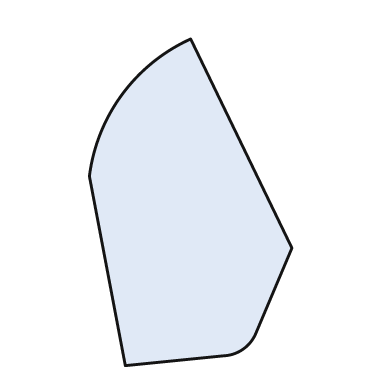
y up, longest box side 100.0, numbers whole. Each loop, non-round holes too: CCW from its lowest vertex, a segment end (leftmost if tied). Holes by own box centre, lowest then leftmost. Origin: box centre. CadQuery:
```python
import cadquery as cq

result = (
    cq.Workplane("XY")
    .moveTo(-20.0, -50.0)
    .lineTo(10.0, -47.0)
    .threePointArc((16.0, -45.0), (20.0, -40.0))
    .lineTo(31.0, -14.0)
    .lineTo(0.0, 50.0)
    .threePointArc((-21.0, 33.0), (-31.0, 8.0))
    .close()
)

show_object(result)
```